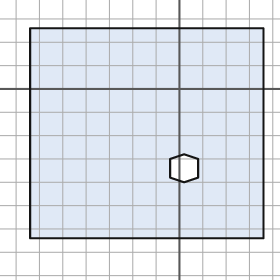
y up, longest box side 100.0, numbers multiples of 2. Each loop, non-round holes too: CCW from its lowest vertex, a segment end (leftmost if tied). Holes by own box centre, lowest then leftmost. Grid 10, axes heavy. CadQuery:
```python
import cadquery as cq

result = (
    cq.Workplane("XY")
    .moveTo(-64.0, -64.0)
    .lineTo(36.0, -64.0)
    .lineTo(36.0, 26.0)
    .lineTo(-64.0, 26.0)
    .close()
    .moveTo(2.0, -40.0)
    .lineTo(8.0, -38.0)
    .lineTo(8.0, -30.0)
    .lineTo(2.0, -28.0)
    .lineTo(-4.0, -30.0)
    .lineTo(-4.0, -38.0)
    .close()
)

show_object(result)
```